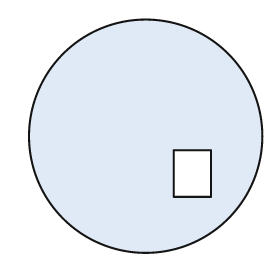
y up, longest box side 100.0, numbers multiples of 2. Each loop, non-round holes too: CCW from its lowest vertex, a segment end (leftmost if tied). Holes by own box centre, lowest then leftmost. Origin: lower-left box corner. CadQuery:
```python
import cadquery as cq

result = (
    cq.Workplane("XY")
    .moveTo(50.0, 50.0)
    .circle(50.0)
    .moveTo(62.0, 24.0)
    .lineTo(78.0, 24.0)
    .lineTo(78.0, 44.0)
    .lineTo(62.0, 44.0)
    .close()
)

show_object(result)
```